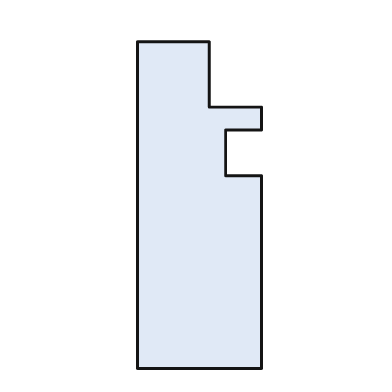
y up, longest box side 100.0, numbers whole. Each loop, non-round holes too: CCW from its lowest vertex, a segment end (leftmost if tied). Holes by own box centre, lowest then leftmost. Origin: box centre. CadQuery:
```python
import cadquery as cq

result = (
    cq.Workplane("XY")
    .moveTo(-19.0, -50.0)
    .lineTo(19.0, -50.0)
    .lineTo(19.0, 9.0)
    .lineTo(8.0, 9.0)
    .lineTo(8.0, 23.0)
    .lineTo(19.0, 23.0)
    .lineTo(19.0, 30.0)
    .lineTo(3.0, 30.0)
    .lineTo(3.0, 50.0)
    .lineTo(-19.0, 50.0)
    .close()
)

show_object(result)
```